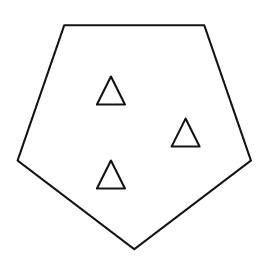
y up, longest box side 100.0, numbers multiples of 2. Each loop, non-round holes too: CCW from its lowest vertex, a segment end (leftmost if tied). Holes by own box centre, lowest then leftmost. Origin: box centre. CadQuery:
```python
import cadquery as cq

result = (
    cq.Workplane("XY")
    .moveTo(0.0, -48.0)
    .lineTo(50.0, -10.0)
    .lineTo(30.0, 48.0)
    .lineTo(-30.0, 48.0)
    .lineTo(-50.0, -10.0)
    .close()
    .moveTo(-16.0, -22.0)
    .lineTo(-4.0, -22.0)
    .lineTo(-10.0, -10.0)
    .close()
    .moveTo(16.0, -4.0)
    .lineTo(28.0, -4.0)
    .lineTo(22.0, 8.0)
    .close()
    .moveTo(-16.0, 14.0)
    .lineTo(-4.0, 14.0)
    .lineTo(-10.0, 26.0)
    .close()
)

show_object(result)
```